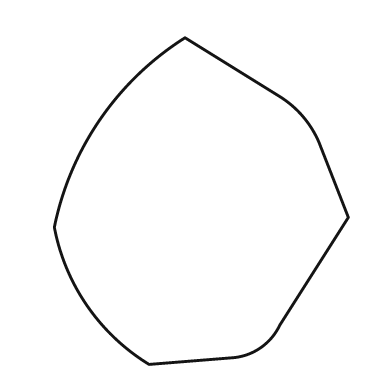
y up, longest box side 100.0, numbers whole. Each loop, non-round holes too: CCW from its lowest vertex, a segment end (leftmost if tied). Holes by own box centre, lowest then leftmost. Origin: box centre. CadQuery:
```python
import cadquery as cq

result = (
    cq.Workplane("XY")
    .moveTo(-16.0, -50.0)
    .lineTo(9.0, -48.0)
    .threePointArc((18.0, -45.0), (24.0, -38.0))
    .lineTo(45.0, -5.0)
    .lineTo(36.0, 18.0)
    .threePointArc((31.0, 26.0), (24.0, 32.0))
    .lineTo(-5.0, 50.0)
    .threePointArc((-31.0, 25.0), (-45.0, -8.0))
    .threePointArc((-35.0, -32.0), (-16.0, -50.0))
    .close()
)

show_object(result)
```